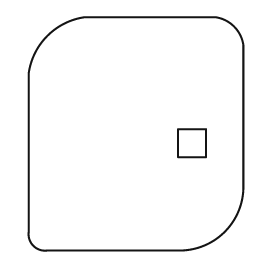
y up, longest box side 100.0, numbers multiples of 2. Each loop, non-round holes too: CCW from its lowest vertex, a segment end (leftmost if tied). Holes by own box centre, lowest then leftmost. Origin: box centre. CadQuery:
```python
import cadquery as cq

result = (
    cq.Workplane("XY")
    .moveTo(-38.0, -50.0)
    .lineTo(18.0, -50.0)
    .threePointArc((38.0, -42.0), (46.0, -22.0))
    .lineTo(46.0, 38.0)
    .threePointArc((42.0, 46.0), (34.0, 50.0))
    .lineTo(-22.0, 50.0)
    .threePointArc((-38.0, 42.0), (-46.0, 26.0))
    .lineTo(-46.0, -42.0)
    .threePointArc((-44.0, -48.0), (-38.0, -50.0))
    .close()
    .moveTo(18.0, -10.0)
    .lineTo(30.0, -10.0)
    .lineTo(30.0, 2.0)
    .lineTo(18.0, 2.0)
    .close()
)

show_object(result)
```